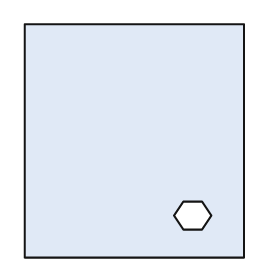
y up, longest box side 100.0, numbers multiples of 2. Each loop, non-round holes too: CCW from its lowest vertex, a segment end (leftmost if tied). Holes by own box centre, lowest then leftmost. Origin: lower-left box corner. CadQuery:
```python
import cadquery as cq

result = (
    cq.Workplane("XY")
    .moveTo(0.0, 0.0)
    .lineTo(94.0, 0.0)
    .lineTo(94.0, 100.0)
    .lineTo(0.0, 100.0)
    .close()
    .moveTo(68.0, 12.0)
    .lineTo(76.0, 12.0)
    .lineTo(80.0, 18.0)
    .lineTo(76.0, 24.0)
    .lineTo(68.0, 24.0)
    .lineTo(64.0, 18.0)
    .close()
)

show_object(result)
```